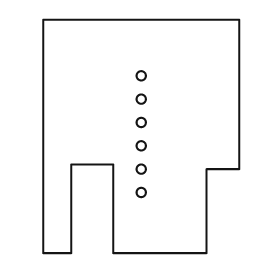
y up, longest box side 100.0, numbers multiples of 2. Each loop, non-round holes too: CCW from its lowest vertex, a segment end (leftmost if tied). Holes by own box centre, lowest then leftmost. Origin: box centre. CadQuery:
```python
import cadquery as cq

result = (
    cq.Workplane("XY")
    .moveTo(-42.0, -50.0)
    .lineTo(-30.0, -50.0)
    .lineTo(-30.0, -12.0)
    .lineTo(-12.0, -12.0)
    .lineTo(-12.0, -50.0)
    .lineTo(28.0, -50.0)
    .lineTo(28.0, -14.0)
    .lineTo(42.0, -14.0)
    .lineTo(42.0, 50.0)
    .lineTo(-42.0, 50.0)
    .close()
    .moveTo(0.0, -24.0)
    .circle(2.0)
    .moveTo(0.0, -14.0)
    .circle(2.0)
    .moveTo(0.0, -4.0)
    .circle(2.0)
    .moveTo(0.0, 6.0)
    .circle(2.0)
    .moveTo(0.0, 16.0)
    .circle(2.0)
    .moveTo(0.0, 26.0)
    .circle(2.0)
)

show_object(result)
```